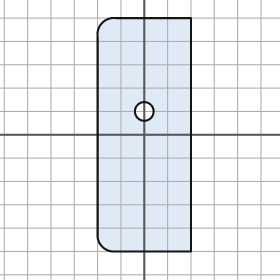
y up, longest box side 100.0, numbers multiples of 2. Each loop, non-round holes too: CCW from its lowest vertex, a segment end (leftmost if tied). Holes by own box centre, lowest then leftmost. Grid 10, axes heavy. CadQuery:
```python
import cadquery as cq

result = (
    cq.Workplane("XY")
    .moveTo(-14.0, -50.0)
    .lineTo(20.0, -50.0)
    .lineTo(20.0, 50.0)
    .lineTo(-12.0, 50.0)
    .threePointArc((-18.0, 48.0), (-20.0, 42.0))
    .lineTo(-20.0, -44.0)
    .threePointArc((-18.0, -48.0), (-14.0, -50.0))
    .close()
    .moveTo(0.0, 10.0)
    .circle(4.0)
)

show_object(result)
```